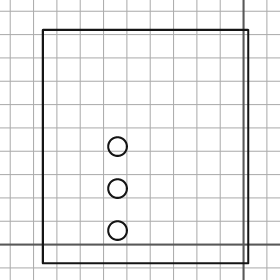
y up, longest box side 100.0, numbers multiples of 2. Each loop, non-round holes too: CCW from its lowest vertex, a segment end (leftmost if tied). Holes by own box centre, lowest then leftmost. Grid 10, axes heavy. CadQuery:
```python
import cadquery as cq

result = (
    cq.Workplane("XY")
    .moveTo(-86.0, -8.0)
    .lineTo(2.0, -8.0)
    .lineTo(2.0, 92.0)
    .lineTo(-86.0, 92.0)
    .close()
    .moveTo(-54.0, 6.0)
    .circle(4.0)
    .moveTo(-54.0, 24.0)
    .circle(4.0)
    .moveTo(-54.0, 42.0)
    .circle(4.0)
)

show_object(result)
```